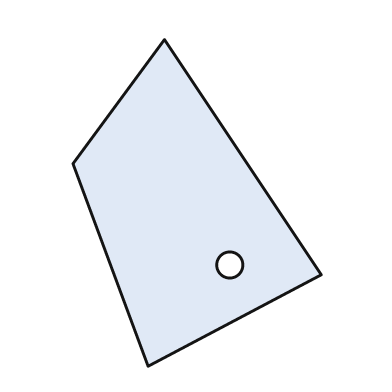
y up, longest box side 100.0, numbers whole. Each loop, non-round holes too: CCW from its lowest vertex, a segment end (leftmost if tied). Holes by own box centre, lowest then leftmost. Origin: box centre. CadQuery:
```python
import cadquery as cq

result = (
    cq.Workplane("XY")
    .moveTo(-15.0, -50.0)
    .lineTo(38.0, -22.0)
    .lineTo(-10.0, 50.0)
    .lineTo(-38.0, 12.0)
    .close()
    .moveTo(10.0, -19.0)
    .circle(4.0)
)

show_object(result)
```